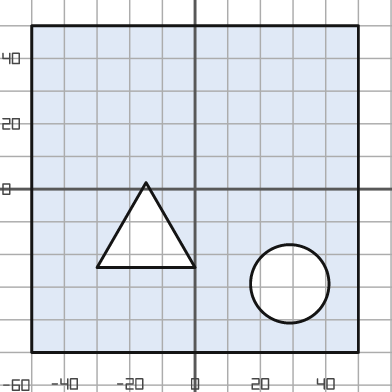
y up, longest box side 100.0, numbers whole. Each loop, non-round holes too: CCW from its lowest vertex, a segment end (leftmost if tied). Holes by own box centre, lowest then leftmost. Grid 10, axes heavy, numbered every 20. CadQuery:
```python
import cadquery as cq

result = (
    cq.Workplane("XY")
    .moveTo(-50.0, -50.0)
    .lineTo(50.0, -50.0)
    .lineTo(50.0, 50.0)
    .lineTo(-50.0, 50.0)
    .close()
    .moveTo(29.0, -29.0)
    .circle(12.0)
    .moveTo(-30.0, -24.0)
    .lineTo(0.0, -24.0)
    .lineTo(-15.0, 2.0)
    .close()
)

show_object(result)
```